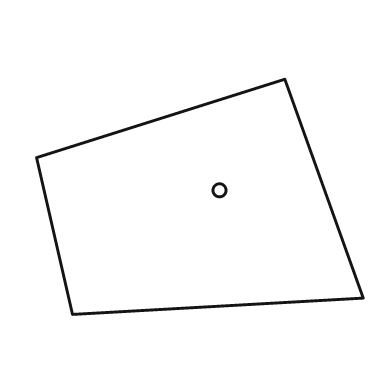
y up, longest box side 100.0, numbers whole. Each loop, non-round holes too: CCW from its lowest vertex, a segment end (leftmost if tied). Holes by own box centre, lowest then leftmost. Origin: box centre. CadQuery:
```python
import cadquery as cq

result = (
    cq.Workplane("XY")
    .moveTo(-39.0, -36.0)
    .lineTo(50.0, -31.0)
    .lineTo(26.0, 36.0)
    .lineTo(-50.0, 12.0)
    .close()
    .moveTo(6.0, 2.0)
    .circle(2.0)
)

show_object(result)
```